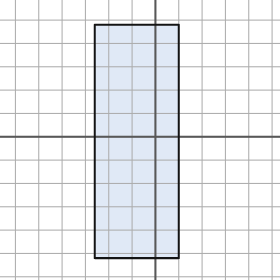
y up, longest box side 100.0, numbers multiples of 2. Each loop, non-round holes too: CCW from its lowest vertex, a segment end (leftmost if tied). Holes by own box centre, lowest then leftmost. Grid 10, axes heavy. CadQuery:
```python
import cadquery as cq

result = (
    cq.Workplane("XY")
    .moveTo(-26.0, -52.0)
    .lineTo(10.0, -52.0)
    .lineTo(10.0, 48.0)
    .lineTo(-26.0, 48.0)
    .close()
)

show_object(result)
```